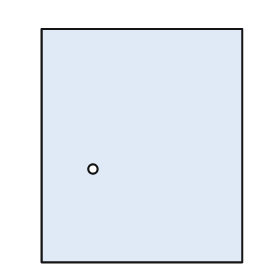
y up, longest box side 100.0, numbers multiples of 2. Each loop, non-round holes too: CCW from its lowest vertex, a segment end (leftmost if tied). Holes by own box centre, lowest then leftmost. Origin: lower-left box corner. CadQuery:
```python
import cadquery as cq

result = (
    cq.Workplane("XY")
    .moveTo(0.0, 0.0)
    .lineTo(86.0, 0.0)
    .lineTo(86.0, 100.0)
    .lineTo(0.0, 100.0)
    .close()
    .moveTo(22.0, 40.0)
    .circle(2.0)
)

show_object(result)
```